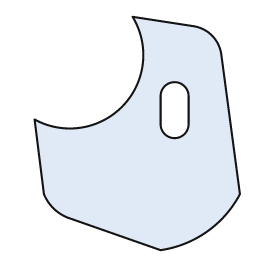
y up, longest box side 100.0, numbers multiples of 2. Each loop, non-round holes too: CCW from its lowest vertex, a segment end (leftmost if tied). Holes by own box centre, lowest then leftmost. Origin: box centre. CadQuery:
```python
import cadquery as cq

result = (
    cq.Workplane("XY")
    .moveTo(10.0, -50.0)
    .threePointArc((30.0, -42.0), (44.0, -26.0))
    .lineTo(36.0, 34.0)
    .threePointArc((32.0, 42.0), (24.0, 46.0))
    .lineTo(-2.0, 50.0)
    .threePointArc((-6.0, 12.0), (-44.0, 6.0))
    .lineTo(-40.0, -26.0)
    .threePointArc((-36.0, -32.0), (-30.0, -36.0))
    .close()
    .moveTo(10.0, 4.0)
    .threePointArc((16.0, -2.0), (22.0, 4.0))
    .lineTo(22.0, 16.0)
    .threePointArc((16.0, 22.0), (10.0, 16.0))
    .close()
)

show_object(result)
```